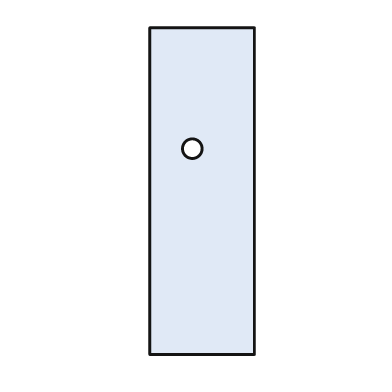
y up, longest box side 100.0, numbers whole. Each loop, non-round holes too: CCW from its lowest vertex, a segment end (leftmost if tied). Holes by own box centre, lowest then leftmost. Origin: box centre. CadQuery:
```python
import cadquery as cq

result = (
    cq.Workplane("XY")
    .moveTo(-16.0, -50.0)
    .lineTo(16.0, -50.0)
    .lineTo(16.0, 50.0)
    .lineTo(-16.0, 50.0)
    .close()
    .moveTo(-3.0, 13.0)
    .circle(3.0)
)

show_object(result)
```